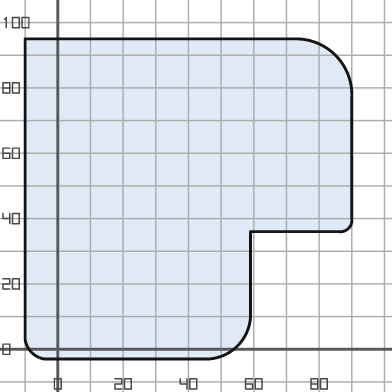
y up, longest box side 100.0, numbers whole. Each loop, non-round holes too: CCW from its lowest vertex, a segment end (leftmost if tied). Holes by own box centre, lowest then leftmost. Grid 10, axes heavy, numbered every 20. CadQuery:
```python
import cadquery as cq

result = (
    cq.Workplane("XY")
    .moveTo(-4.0, -3.0)
    .lineTo(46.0, -3.0)
    .threePointArc((55.0, 1.0), (59.0, 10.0))
    .lineTo(59.0, 36.0)
    .lineTo(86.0, 36.0)
    .threePointArc((89.0, 37.0), (90.0, 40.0))
    .lineTo(90.0, 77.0)
    .threePointArc((85.0, 90.0), (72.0, 95.0))
    .lineTo(-10.0, 95.0)
    .lineTo(-10.0, 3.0)
    .threePointArc((-8.0, -1.0), (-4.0, -3.0))
    .close()
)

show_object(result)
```